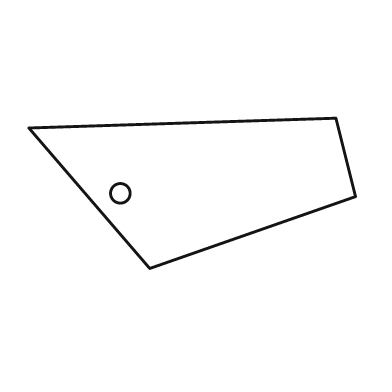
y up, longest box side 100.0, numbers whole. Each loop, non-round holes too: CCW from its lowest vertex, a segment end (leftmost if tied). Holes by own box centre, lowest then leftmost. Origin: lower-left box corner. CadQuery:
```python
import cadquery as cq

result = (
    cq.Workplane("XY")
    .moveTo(37.0, 0.0)
    .lineTo(100.0, 22.0)
    .lineTo(94.0, 46.0)
    .lineTo(0.0, 43.0)
    .close()
    .moveTo(28.0, 23.0)
    .circle(3.0)
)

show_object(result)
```